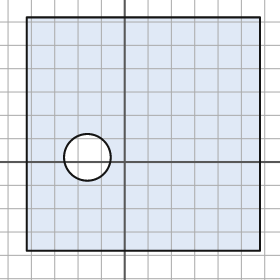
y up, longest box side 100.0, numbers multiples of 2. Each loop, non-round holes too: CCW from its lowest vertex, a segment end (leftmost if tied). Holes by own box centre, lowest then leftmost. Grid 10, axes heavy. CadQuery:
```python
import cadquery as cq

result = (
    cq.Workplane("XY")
    .moveTo(-42.0, -38.0)
    .lineTo(58.0, -38.0)
    .lineTo(58.0, 62.0)
    .lineTo(-42.0, 62.0)
    .close()
    .moveTo(-16.0, 2.0)
    .circle(10.0)
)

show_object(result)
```